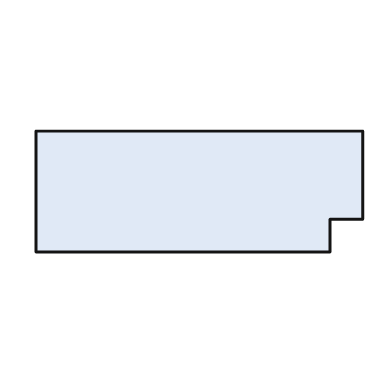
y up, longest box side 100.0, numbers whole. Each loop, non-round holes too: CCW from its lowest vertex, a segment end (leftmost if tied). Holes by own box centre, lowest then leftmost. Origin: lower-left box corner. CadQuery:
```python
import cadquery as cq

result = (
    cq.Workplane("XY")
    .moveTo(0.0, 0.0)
    .lineTo(90.0, 0.0)
    .lineTo(90.0, 10.0)
    .lineTo(100.0, 10.0)
    .lineTo(100.0, 37.0)
    .lineTo(0.0, 37.0)
    .close()
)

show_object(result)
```